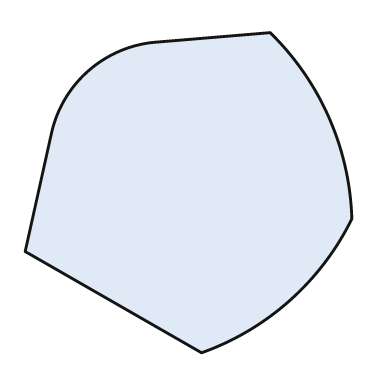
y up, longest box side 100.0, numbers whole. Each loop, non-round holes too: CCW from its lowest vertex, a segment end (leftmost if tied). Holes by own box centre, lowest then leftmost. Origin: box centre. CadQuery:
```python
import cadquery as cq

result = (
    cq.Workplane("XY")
    .moveTo(4.0, -49.0)
    .threePointArc((31.0, -33.0), (50.0, -8.0))
    .threePointArc((43.0, 23.0), (25.0, 49.0))
    .lineTo(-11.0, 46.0)
    .threePointArc((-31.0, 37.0), (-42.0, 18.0))
    .lineTo(-50.0, -18.0)
    .close()
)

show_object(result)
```